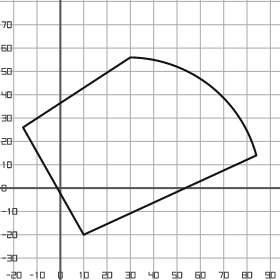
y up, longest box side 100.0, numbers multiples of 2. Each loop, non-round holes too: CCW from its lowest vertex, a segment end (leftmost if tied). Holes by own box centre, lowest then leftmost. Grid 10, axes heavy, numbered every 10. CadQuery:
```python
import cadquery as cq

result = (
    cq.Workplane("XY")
    .moveTo(10.0, -20.0)
    .lineTo(84.0, 14.0)
    .threePointArc((64.0, 44.0), (30.0, 56.0))
    .lineTo(-16.0, 26.0)
    .close()
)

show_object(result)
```